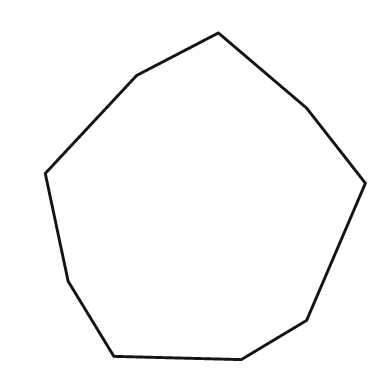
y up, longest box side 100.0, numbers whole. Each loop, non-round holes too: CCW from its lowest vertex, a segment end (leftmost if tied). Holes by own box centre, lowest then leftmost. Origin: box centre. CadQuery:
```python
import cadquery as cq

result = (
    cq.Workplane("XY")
    .moveTo(11.0, -50.0)
    .lineTo(31.0, -38.0)
    .lineTo(49.0, 4.0)
    .lineTo(31.0, 27.0)
    .lineTo(4.0, 50.0)
    .lineTo(-21.0, 37.0)
    .lineTo(-49.0, 7.0)
    .lineTo(-42.0, -26.0)
    .lineTo(-28.0, -49.0)
    .close()
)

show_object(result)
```